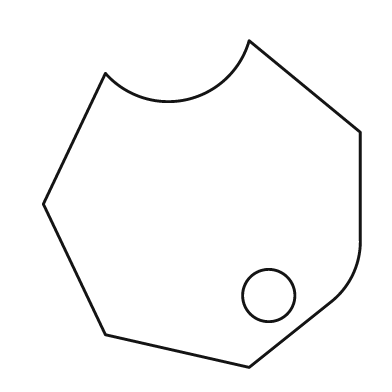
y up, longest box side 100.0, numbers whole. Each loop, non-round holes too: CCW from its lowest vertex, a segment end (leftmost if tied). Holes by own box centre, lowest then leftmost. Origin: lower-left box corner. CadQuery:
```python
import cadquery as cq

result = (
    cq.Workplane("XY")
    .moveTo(63.0, 0.0)
    .lineTo(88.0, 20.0)
    .threePointArc((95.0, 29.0), (97.0, 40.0))
    .lineTo(97.0, 72.0)
    .lineTo(63.0, 100.0)
    .threePointArc((44.0, 82.0), (19.0, 90.0))
    .lineTo(0.0, 50.0)
    .lineTo(19.0, 10.0)
    .close()
    .moveTo(69.0, 22.0)
    .circle(8.0)
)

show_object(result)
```